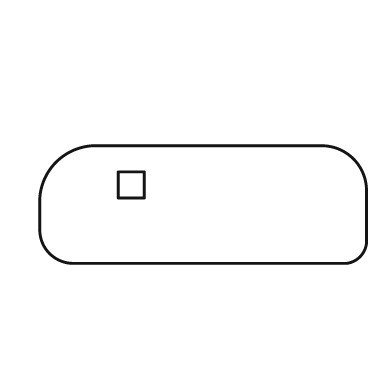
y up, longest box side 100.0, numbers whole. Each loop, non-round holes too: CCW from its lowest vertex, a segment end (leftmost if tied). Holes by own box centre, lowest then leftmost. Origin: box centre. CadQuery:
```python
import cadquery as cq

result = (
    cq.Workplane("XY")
    .moveTo(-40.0, -18.0)
    .lineTo(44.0, -18.0)
    .threePointArc((48.0, -16.0), (50.0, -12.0))
    .lineTo(50.0, 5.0)
    .threePointArc((46.0, 14.0), (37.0, 18.0))
    .lineTo(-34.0, 18.0)
    .threePointArc((-45.0, 13.0), (-50.0, 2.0))
    .lineTo(-50.0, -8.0)
    .threePointArc((-47.0, -15.0), (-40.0, -18.0))
    .close()
    .moveTo(-26.0, 2.0)
    .lineTo(-18.0, 2.0)
    .lineTo(-18.0, 10.0)
    .lineTo(-26.0, 10.0)
    .close()
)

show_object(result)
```